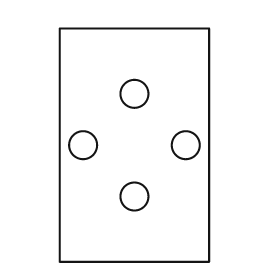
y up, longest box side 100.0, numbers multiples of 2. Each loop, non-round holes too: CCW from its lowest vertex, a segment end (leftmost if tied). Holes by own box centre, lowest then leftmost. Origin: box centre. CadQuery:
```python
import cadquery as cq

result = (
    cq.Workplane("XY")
    .moveTo(-32.0, -50.0)
    .lineTo(32.0, -50.0)
    .lineTo(32.0, 50.0)
    .lineTo(-32.0, 50.0)
    .close()
    .moveTo(0.0, -22.0)
    .circle(6.0)
    .moveTo(-22.0, 0.0)
    .circle(6.0)
    .moveTo(22.0, 0.0)
    .circle(6.0)
    .moveTo(0.0, 22.0)
    .circle(6.0)
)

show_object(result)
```